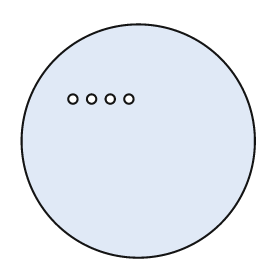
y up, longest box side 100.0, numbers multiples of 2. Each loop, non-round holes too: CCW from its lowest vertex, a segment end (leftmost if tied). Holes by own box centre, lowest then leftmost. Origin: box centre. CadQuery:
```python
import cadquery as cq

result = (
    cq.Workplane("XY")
    .moveTo(0.0, 0.0)
    .circle(50.0)
    .moveTo(-28.0, 18.0)
    .circle(2.0)
    .moveTo(-20.0, 18.0)
    .circle(2.0)
    .moveTo(-12.0, 18.0)
    .circle(2.0)
    .moveTo(-4.0, 18.0)
    .circle(2.0)
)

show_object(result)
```